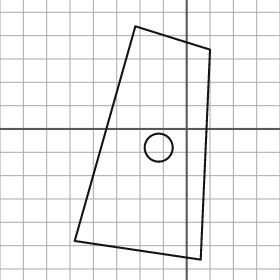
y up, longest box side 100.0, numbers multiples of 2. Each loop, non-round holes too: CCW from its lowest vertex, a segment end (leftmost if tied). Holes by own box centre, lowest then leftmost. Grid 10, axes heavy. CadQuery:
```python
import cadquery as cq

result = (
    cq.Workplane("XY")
    .moveTo(6.0, -56.0)
    .lineTo(10.0, 34.0)
    .lineTo(-22.0, 44.0)
    .lineTo(-48.0, -48.0)
    .close()
    .moveTo(-12.0, -8.0)
    .circle(6.0)
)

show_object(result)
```